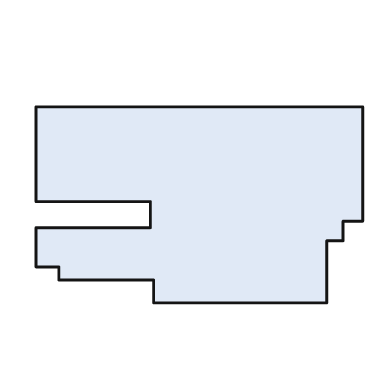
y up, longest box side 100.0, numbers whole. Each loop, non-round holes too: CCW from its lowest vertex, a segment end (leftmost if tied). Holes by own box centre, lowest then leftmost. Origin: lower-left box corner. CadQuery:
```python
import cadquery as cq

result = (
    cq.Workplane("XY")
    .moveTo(36.0, 0.0)
    .lineTo(89.0, 0.0)
    .lineTo(89.0, 19.0)
    .lineTo(94.0, 19.0)
    .lineTo(94.0, 25.0)
    .lineTo(100.0, 25.0)
    .lineTo(100.0, 60.0)
    .lineTo(0.0, 60.0)
    .lineTo(0.0, 31.0)
    .lineTo(35.0, 31.0)
    .lineTo(35.0, 23.0)
    .lineTo(0.0, 23.0)
    .lineTo(0.0, 11.0)
    .lineTo(7.0, 11.0)
    .lineTo(7.0, 7.0)
    .lineTo(36.0, 7.0)
    .close()
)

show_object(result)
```